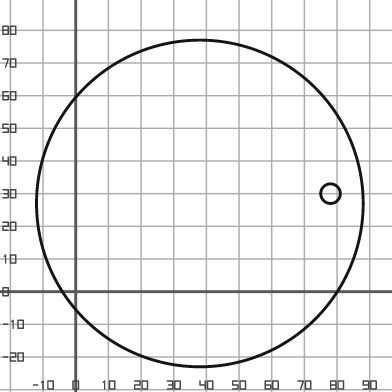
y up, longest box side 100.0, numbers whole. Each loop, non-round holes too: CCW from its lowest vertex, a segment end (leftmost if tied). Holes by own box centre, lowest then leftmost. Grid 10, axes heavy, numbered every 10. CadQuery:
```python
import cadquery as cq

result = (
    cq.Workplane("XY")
    .moveTo(38.0, 27.0)
    .circle(50.0)
    .moveTo(78.0, 30.0)
    .circle(3.0)
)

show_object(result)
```